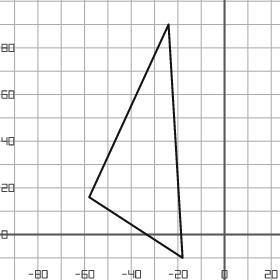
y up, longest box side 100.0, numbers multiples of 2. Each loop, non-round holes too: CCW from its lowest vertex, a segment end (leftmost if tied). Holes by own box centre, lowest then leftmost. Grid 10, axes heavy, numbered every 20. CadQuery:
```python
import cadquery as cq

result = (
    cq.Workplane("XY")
    .moveTo(-18.0, -10.0)
    .lineTo(-24.0, 90.0)
    .lineTo(-58.0, 16.0)
    .close()
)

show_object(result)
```